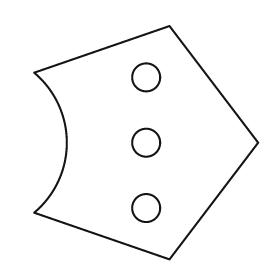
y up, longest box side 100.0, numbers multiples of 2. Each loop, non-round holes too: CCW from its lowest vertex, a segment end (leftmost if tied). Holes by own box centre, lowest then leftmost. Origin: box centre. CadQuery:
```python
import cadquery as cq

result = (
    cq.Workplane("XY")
    .moveTo(10.0, -50.0)
    .lineTo(48.0, 0.0)
    .lineTo(10.0, 50.0)
    .lineTo(-48.0, 30.0)
    .threePointArc((-34.0, 0.0), (-48.0, -30.0))
    .close()
    .moveTo(0.0, -28.0)
    .circle(6.0)
    .moveTo(0.0, 0.0)
    .circle(6.0)
    .moveTo(0.0, 28.0)
    .circle(6.0)
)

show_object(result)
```